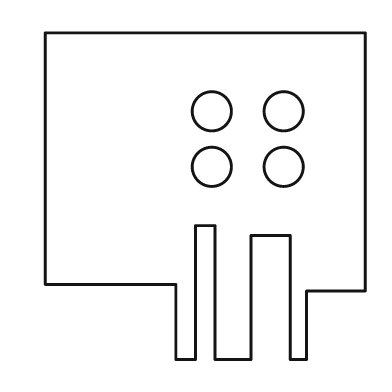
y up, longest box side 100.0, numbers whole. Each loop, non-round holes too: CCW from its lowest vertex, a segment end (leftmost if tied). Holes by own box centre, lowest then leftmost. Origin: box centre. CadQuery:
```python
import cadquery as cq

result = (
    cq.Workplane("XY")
    .moveTo(-9.0, -50.0)
    .lineTo(-3.0, -50.0)
    .lineTo(-3.0, -9.0)
    .lineTo(3.0, -9.0)
    .lineTo(3.0, -50.0)
    .lineTo(14.0, -50.0)
    .lineTo(14.0, -12.0)
    .lineTo(26.0, -12.0)
    .lineTo(26.0, -50.0)
    .lineTo(31.0, -50.0)
    .lineTo(31.0, -29.0)
    .lineTo(49.0, -29.0)
    .lineTo(49.0, 50.0)
    .lineTo(-49.0, 50.0)
    .lineTo(-49.0, -27.0)
    .lineTo(-9.0, -27.0)
    .close()
    .moveTo(2.0, 9.0)
    .circle(6.0)
    .moveTo(24.0, 9.0)
    .circle(6.0)
    .moveTo(2.0, 26.0)
    .circle(6.0)
    .moveTo(24.0, 26.0)
    .circle(6.0)
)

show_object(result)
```